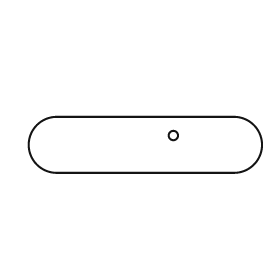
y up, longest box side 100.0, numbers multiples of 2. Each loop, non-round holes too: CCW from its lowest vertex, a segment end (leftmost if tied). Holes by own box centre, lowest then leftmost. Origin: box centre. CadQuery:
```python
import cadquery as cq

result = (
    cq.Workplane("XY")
    .moveTo(-38.0, -12.0)
    .lineTo(38.0, -12.0)
    .threePointArc((50.0, 0.0), (38.0, 12.0))
    .lineTo(-38.0, 12.0)
    .threePointArc((-50.0, 0.0), (-38.0, -12.0))
    .close()
    .moveTo(12.0, 4.0)
    .circle(2.0)
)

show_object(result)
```